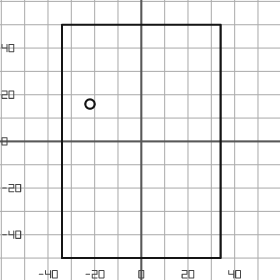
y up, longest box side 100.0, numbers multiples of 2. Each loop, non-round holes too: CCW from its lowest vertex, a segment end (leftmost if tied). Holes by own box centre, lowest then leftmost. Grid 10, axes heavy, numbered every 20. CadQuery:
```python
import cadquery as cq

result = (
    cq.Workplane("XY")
    .moveTo(-34.0, -50.0)
    .lineTo(34.0, -50.0)
    .lineTo(34.0, 50.0)
    .lineTo(-34.0, 50.0)
    .close()
    .moveTo(-22.0, 16.0)
    .circle(2.0)
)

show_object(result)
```